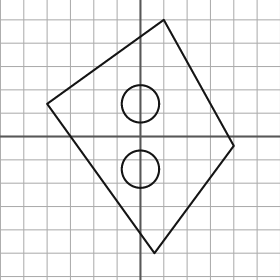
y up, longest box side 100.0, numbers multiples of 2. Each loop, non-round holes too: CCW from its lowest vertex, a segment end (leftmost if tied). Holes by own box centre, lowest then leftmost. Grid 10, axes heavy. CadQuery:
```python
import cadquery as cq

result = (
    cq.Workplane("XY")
    .moveTo(6.0, -50.0)
    .lineTo(40.0, -4.0)
    .lineTo(10.0, 50.0)
    .lineTo(-40.0, 14.0)
    .close()
    .moveTo(0.0, -14.0)
    .circle(8.0)
    .moveTo(0.0, 14.0)
    .circle(8.0)
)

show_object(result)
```